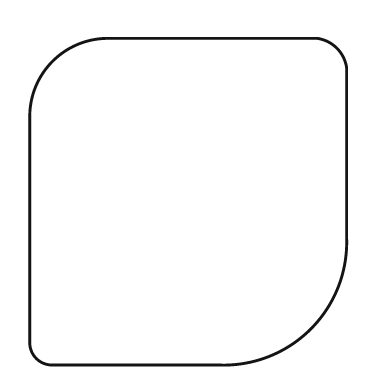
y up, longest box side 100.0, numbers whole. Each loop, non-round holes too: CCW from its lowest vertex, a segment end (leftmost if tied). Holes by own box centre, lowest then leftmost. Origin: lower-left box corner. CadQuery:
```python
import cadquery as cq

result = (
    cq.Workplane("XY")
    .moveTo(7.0, 0.0)
    .lineTo(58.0, 0.0)
    .threePointArc((86.0, 11.0), (97.0, 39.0))
    .lineTo(97.0, 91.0)
    .threePointArc((94.0, 97.0), (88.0, 100.0))
    .lineTo(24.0, 100.0)
    .threePointArc((7.0, 93.0), (0.0, 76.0))
    .lineTo(0.0, 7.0)
    .threePointArc((2.0, 2.0), (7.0, 0.0))
    .close()
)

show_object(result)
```